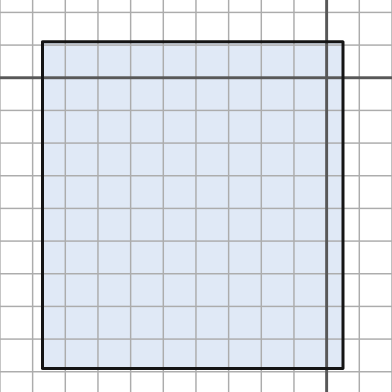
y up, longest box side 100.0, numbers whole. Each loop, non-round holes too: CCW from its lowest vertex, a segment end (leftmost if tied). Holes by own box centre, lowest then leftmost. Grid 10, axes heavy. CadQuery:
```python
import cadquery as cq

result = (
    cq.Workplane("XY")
    .moveTo(-87.0, -89.0)
    .lineTo(5.0, -89.0)
    .lineTo(5.0, 11.0)
    .lineTo(-87.0, 11.0)
    .close()
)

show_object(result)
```